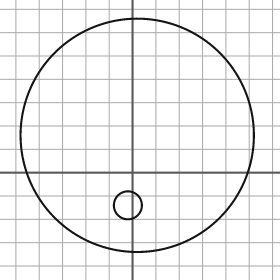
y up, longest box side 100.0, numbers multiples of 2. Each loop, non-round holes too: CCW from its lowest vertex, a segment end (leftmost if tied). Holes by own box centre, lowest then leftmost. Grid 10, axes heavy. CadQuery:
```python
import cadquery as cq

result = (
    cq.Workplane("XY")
    .moveTo(2.0, 16.0)
    .circle(50.0)
    .moveTo(-2.0, -14.0)
    .circle(6.0)
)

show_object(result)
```